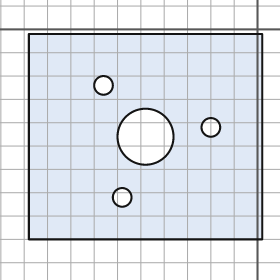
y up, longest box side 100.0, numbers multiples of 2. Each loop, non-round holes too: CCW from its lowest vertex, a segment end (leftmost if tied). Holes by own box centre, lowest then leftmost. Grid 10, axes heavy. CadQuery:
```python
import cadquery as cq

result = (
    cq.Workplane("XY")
    .moveTo(-98.0, -90.0)
    .lineTo(2.0, -90.0)
    .lineTo(2.0, -2.0)
    .lineTo(-98.0, -2.0)
    .close()
    .moveTo(-58.0, -72.0)
    .circle(4.0)
    .moveTo(-48.0, -46.0)
    .circle(12.0)
    .moveTo(-20.0, -42.0)
    .circle(4.0)
    .moveTo(-66.0, -24.0)
    .circle(4.0)
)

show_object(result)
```